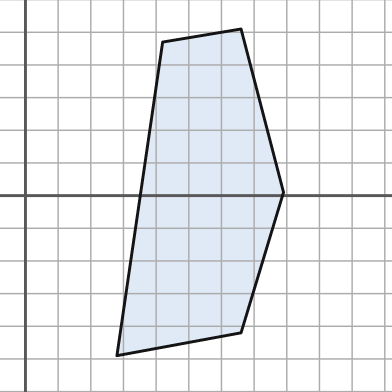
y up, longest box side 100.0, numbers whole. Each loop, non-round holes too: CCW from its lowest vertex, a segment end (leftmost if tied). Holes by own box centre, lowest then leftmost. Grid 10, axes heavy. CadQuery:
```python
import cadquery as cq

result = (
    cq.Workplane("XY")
    .moveTo(28.0, -49.0)
    .lineTo(66.0, -42.0)
    .lineTo(79.0, 1.0)
    .lineTo(66.0, 51.0)
    .lineTo(42.0, 47.0)
    .close()
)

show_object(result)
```